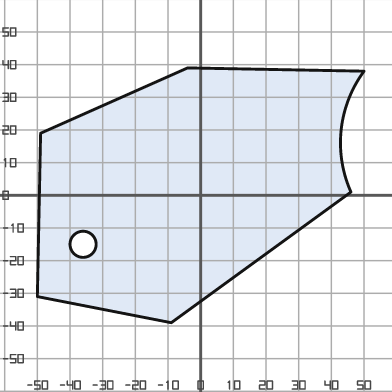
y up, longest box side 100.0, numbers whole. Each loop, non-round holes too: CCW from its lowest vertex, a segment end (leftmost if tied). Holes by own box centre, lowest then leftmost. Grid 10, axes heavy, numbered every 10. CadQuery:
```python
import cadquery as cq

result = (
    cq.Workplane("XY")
    .moveTo(-9.0, -39.0)
    .lineTo(46.0, 1.0)
    .threePointArc((43.0, 20.0), (50.0, 38.0))
    .lineTo(-4.0, 39.0)
    .lineTo(-49.0, 19.0)
    .lineTo(-50.0, -31.0)
    .close()
    .moveTo(-36.0, -15.0)
    .circle(4.0)
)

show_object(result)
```